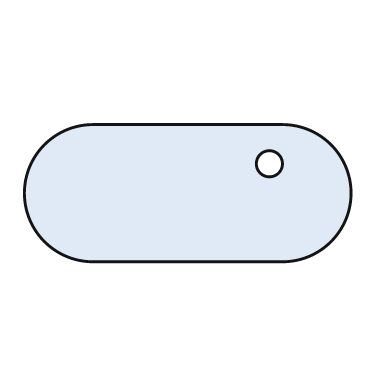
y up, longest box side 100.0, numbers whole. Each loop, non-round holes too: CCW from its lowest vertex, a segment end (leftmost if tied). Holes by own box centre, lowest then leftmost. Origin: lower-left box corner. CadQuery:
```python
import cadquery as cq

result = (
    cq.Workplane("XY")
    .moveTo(21.0, 0.0)
    .lineTo(79.0, 0.0)
    .threePointArc((100.0, 21.0), (79.0, 42.0))
    .lineTo(21.0, 42.0)
    .threePointArc((0.0, 21.0), (21.0, 0.0))
    .close()
    .moveTo(75.0, 30.0)
    .circle(4.0)
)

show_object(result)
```